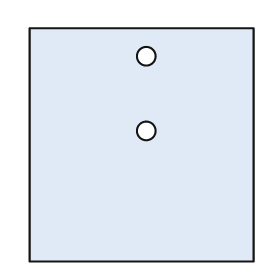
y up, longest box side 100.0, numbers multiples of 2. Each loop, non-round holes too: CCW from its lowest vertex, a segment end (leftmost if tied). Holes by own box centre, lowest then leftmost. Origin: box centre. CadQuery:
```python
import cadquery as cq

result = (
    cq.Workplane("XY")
    .moveTo(-48.0, -50.0)
    .lineTo(48.0, -50.0)
    .lineTo(48.0, 50.0)
    .lineTo(-48.0, 50.0)
    .close()
    .moveTo(2.0, 6.0)
    .circle(4.0)
    .moveTo(2.0, 38.0)
    .circle(4.0)
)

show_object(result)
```